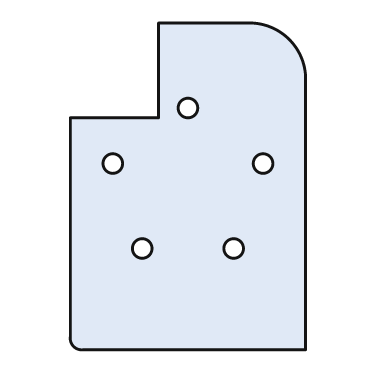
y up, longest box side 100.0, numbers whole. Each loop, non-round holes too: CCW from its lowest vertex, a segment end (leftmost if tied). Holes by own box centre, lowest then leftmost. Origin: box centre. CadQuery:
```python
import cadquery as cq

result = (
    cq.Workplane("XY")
    .moveTo(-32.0, -50.0)
    .lineTo(36.0, -50.0)
    .lineTo(36.0, 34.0)
    .threePointArc((31.0, 45.0), (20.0, 50.0))
    .lineTo(-9.0, 50.0)
    .lineTo(-9.0, 21.0)
    .lineTo(-36.0, 21.0)
    .lineTo(-36.0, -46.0)
    .threePointArc((-35.0, -49.0), (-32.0, -50.0))
    .close()
    .moveTo(-14.0, -19.0)
    .circle(3.0)
    .moveTo(14.0, -19.0)
    .circle(3.0)
    .moveTo(-23.0, 7.0)
    .circle(3.0)
    .moveTo(23.0, 7.0)
    .circle(3.0)
    .moveTo(0.0, 24.0)
    .circle(3.0)
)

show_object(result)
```